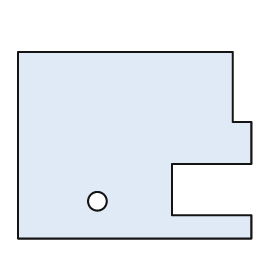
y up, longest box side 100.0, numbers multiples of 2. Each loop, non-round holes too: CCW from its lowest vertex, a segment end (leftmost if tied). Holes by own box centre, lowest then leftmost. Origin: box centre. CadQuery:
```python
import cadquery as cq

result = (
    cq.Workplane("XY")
    .moveTo(-50.0, -40.0)
    .lineTo(50.0, -40.0)
    .lineTo(50.0, -30.0)
    .lineTo(16.0, -30.0)
    .lineTo(16.0, -8.0)
    .lineTo(50.0, -8.0)
    .lineTo(50.0, 10.0)
    .lineTo(42.0, 10.0)
    .lineTo(42.0, 40.0)
    .lineTo(-50.0, 40.0)
    .close()
    .moveTo(-16.0, -24.0)
    .circle(4.0)
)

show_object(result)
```